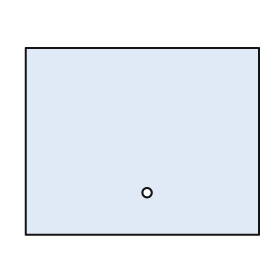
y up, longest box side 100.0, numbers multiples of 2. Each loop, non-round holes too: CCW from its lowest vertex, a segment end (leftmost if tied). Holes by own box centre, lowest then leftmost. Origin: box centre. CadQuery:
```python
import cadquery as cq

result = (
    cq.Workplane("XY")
    .moveTo(-50.0, -40.0)
    .lineTo(50.0, -40.0)
    .lineTo(50.0, 40.0)
    .lineTo(-50.0, 40.0)
    .close()
    .moveTo(2.0, -22.0)
    .circle(2.0)
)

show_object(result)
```